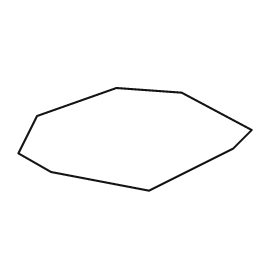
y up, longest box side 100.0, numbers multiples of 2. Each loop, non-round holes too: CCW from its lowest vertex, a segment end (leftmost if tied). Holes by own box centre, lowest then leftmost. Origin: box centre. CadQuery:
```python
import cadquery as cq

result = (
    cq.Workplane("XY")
    .moveTo(6.0, -22.0)
    .lineTo(42.0, -4.0)
    .lineTo(50.0, 4.0)
    .lineTo(20.0, 20.0)
    .lineTo(-8.0, 22.0)
    .lineTo(-42.0, 10.0)
    .lineTo(-50.0, -6.0)
    .lineTo(-36.0, -14.0)
    .close()
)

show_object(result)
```